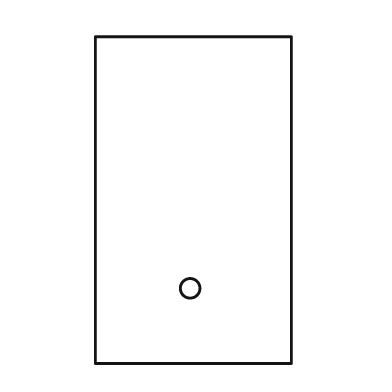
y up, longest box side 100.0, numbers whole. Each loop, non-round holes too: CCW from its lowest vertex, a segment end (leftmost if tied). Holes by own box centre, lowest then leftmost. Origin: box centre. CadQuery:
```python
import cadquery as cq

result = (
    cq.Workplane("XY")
    .moveTo(-30.0, -50.0)
    .lineTo(30.0, -50.0)
    .lineTo(30.0, 50.0)
    .lineTo(-30.0, 50.0)
    .close()
    .moveTo(-1.0, -27.0)
    .circle(3.0)
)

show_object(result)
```